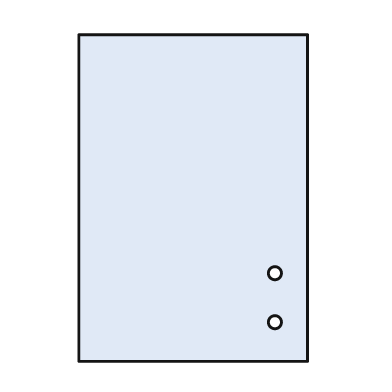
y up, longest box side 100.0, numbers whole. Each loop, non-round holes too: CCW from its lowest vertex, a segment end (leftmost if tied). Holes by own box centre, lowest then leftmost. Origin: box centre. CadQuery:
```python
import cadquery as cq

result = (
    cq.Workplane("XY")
    .moveTo(-35.0, -50.0)
    .lineTo(35.0, -50.0)
    .lineTo(35.0, 50.0)
    .lineTo(-35.0, 50.0)
    .close()
    .moveTo(25.0, -38.0)
    .circle(2.0)
    .moveTo(25.0, -23.0)
    .circle(2.0)
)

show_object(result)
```